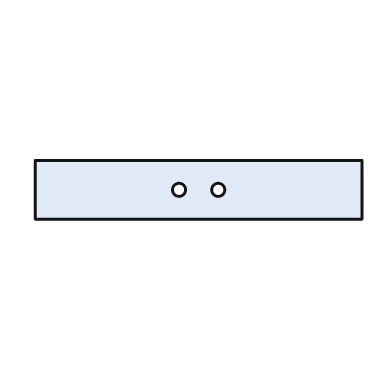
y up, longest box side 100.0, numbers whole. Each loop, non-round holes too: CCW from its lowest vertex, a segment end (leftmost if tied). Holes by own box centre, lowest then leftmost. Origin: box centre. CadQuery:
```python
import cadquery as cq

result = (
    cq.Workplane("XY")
    .moveTo(-50.0, -9.0)
    .lineTo(50.0, -9.0)
    .lineTo(50.0, 9.0)
    .lineTo(-50.0, 9.0)
    .close()
    .moveTo(-6.0, 0.0)
    .circle(2.0)
    .moveTo(6.0, 0.0)
    .circle(2.0)
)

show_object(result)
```